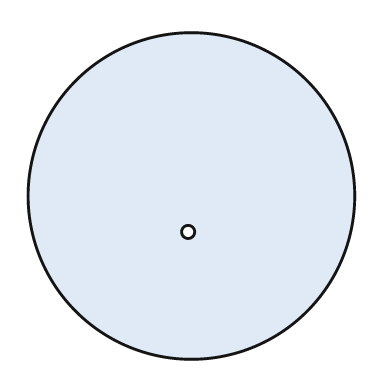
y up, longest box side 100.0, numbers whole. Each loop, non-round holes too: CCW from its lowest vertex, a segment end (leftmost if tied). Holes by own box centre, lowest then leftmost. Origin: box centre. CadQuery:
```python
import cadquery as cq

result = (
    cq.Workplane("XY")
    .moveTo(0.0, 0.0)
    .circle(50.0)
    .moveTo(-1.0, -11.0)
    .circle(2.0)
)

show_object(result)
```